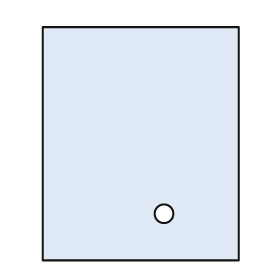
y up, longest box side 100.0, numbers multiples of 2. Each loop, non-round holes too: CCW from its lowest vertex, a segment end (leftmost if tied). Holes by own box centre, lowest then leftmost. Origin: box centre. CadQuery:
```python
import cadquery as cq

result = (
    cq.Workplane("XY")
    .moveTo(-42.0, -50.0)
    .lineTo(42.0, -50.0)
    .lineTo(42.0, 50.0)
    .lineTo(-42.0, 50.0)
    .close()
    .moveTo(10.0, -30.0)
    .circle(4.0)
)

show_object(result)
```